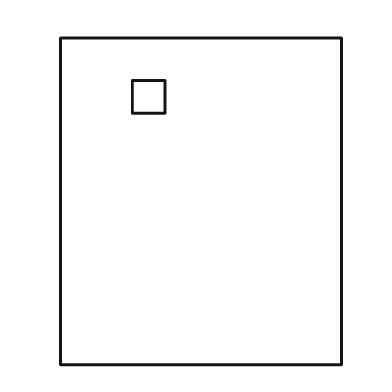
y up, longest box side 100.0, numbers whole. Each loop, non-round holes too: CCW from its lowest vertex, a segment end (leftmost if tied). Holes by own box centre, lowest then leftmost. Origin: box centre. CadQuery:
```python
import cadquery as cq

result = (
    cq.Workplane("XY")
    .moveTo(-43.0, -50.0)
    .lineTo(43.0, -50.0)
    .lineTo(43.0, 50.0)
    .lineTo(-43.0, 50.0)
    .close()
    .moveTo(-21.0, 27.0)
    .lineTo(-11.0, 27.0)
    .lineTo(-11.0, 37.0)
    .lineTo(-21.0, 37.0)
    .close()
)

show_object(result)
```